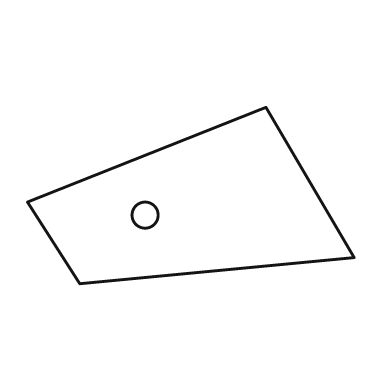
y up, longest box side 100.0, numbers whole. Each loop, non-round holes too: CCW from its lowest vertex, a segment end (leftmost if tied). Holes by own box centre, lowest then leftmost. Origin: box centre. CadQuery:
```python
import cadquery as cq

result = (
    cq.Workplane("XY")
    .moveTo(-34.0, -27.0)
    .lineTo(50.0, -19.0)
    .lineTo(23.0, 27.0)
    .lineTo(-50.0, -2.0)
    .close()
    .moveTo(-14.0, -6.0)
    .circle(4.0)
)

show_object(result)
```